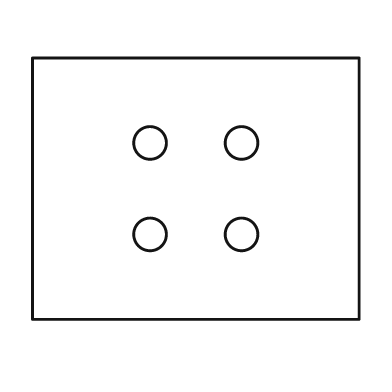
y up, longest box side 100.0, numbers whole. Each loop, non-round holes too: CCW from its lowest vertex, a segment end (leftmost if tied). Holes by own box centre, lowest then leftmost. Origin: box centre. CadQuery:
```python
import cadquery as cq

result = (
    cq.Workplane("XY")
    .moveTo(-50.0, -40.0)
    .lineTo(50.0, -40.0)
    .lineTo(50.0, 40.0)
    .lineTo(-50.0, 40.0)
    .close()
    .moveTo(-14.0, -14.0)
    .circle(5.0)
    .moveTo(14.0, -14.0)
    .circle(5.0)
    .moveTo(-14.0, 14.0)
    .circle(5.0)
    .moveTo(14.0, 14.0)
    .circle(5.0)
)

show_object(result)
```